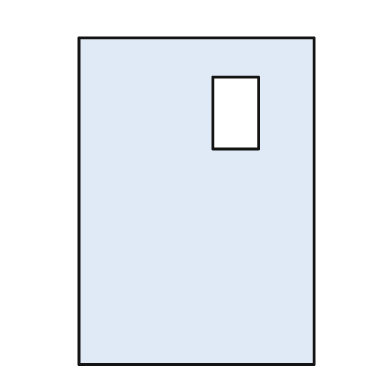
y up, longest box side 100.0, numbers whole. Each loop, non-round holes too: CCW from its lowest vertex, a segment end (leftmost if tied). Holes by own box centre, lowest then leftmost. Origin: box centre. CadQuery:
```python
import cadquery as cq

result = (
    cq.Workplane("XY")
    .moveTo(-36.0, -50.0)
    .lineTo(36.0, -50.0)
    .lineTo(36.0, 50.0)
    .lineTo(-36.0, 50.0)
    .close()
    .moveTo(5.0, 16.0)
    .lineTo(19.0, 16.0)
    .lineTo(19.0, 38.0)
    .lineTo(5.0, 38.0)
    .close()
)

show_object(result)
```